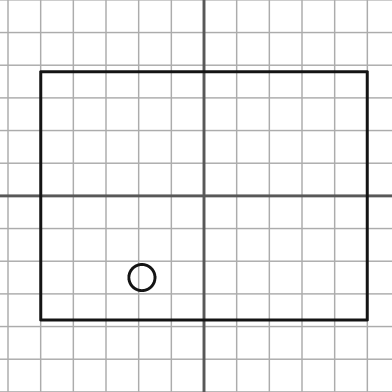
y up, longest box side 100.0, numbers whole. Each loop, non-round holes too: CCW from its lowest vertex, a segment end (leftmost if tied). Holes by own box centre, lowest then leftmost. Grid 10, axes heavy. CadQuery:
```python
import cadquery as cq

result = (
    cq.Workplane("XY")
    .moveTo(-50.0, -38.0)
    .lineTo(50.0, -38.0)
    .lineTo(50.0, 38.0)
    .lineTo(-50.0, 38.0)
    .close()
    .moveTo(-19.0, -25.0)
    .circle(4.0)
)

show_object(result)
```